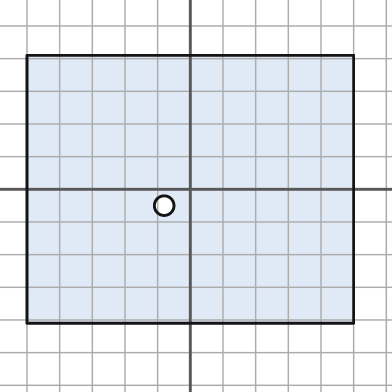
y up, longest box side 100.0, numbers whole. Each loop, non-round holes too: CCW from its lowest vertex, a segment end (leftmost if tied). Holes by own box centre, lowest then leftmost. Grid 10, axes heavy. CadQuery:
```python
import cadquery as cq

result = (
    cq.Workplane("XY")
    .moveTo(-50.0, -41.0)
    .lineTo(50.0, -41.0)
    .lineTo(50.0, 41.0)
    .lineTo(-50.0, 41.0)
    .close()
    .moveTo(-8.0, -5.0)
    .circle(3.0)
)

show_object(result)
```